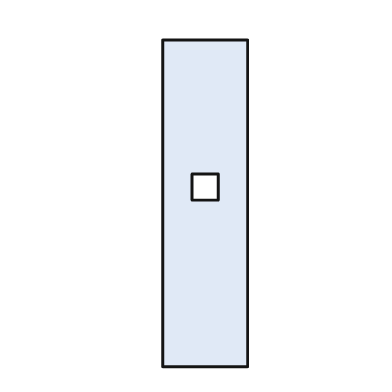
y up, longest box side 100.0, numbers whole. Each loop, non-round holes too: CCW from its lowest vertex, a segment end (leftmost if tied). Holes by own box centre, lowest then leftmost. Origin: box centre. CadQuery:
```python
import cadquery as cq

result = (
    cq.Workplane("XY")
    .moveTo(-13.0, -50.0)
    .lineTo(13.0, -50.0)
    .lineTo(13.0, 50.0)
    .lineTo(-13.0, 50.0)
    .close()
    .moveTo(-4.0, 1.0)
    .lineTo(4.0, 1.0)
    .lineTo(4.0, 9.0)
    .lineTo(-4.0, 9.0)
    .close()
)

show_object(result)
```